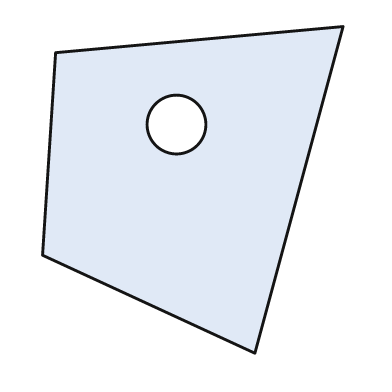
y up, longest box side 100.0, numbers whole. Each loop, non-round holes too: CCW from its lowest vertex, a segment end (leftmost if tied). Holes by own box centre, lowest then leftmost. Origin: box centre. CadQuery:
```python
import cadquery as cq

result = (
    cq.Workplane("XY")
    .moveTo(19.0, -50.0)
    .lineTo(46.0, 50.0)
    .lineTo(-42.0, 42.0)
    .lineTo(-46.0, -20.0)
    .close()
    .moveTo(-5.0, 20.0)
    .circle(9.0)
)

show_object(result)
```